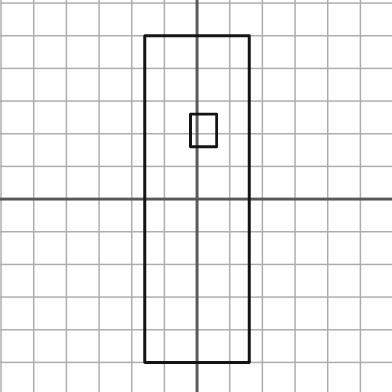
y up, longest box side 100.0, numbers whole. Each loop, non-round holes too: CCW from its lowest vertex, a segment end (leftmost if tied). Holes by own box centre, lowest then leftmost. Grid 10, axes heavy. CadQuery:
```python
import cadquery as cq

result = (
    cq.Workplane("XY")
    .moveTo(-16.0, -50.0)
    .lineTo(16.0, -50.0)
    .lineTo(16.0, 50.0)
    .lineTo(-16.0, 50.0)
    .close()
    .moveTo(-2.0, 16.0)
    .lineTo(6.0, 16.0)
    .lineTo(6.0, 26.0)
    .lineTo(-2.0, 26.0)
    .close()
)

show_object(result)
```